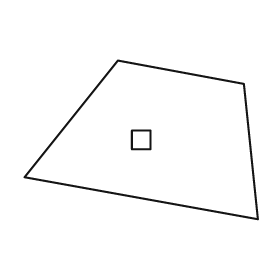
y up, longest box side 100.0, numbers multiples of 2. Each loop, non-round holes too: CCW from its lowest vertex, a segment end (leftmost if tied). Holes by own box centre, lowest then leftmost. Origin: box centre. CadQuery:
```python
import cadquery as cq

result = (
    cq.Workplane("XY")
    .moveTo(50.0, -34.0)
    .lineTo(44.0, 24.0)
    .lineTo(-10.0, 34.0)
    .lineTo(-50.0, -16.0)
    .close()
    .moveTo(-4.0, -4.0)
    .lineTo(4.0, -4.0)
    .lineTo(4.0, 4.0)
    .lineTo(-4.0, 4.0)
    .close()
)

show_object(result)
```